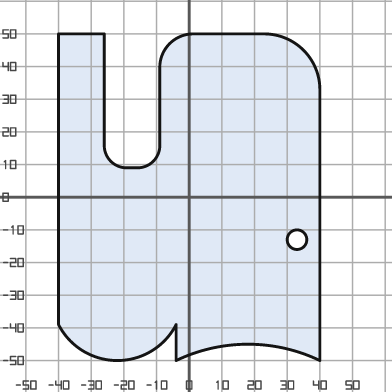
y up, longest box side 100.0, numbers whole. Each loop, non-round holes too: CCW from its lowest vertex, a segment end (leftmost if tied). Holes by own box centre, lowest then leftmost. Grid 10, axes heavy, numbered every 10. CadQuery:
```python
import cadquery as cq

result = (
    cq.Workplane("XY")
    .moveTo(-4.0, -50.0)
    .threePointArc((18.0, -45.0), (40.0, -50.0))
    .lineTo(40.0, 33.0)
    .threePointArc((35.0, 45.0), (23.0, 50.0))
    .lineTo(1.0, 50.0)
    .threePointArc((-6.0, 47.0), (-9.0, 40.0))
    .lineTo(-9.0, 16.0)
    .threePointArc((-11.0, 11.0), (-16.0, 9.0))
    .lineTo(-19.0, 9.0)
    .threePointArc((-24.0, 11.0), (-26.0, 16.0))
    .lineTo(-26.0, 50.0)
    .lineTo(-40.0, 50.0)
    .lineTo(-40.0, -39.0)
    .threePointArc((-22.0, -50.0), (-4.0, -39.0))
    .close()
    .moveTo(33.0, -13.0)
    .circle(3.0)
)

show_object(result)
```